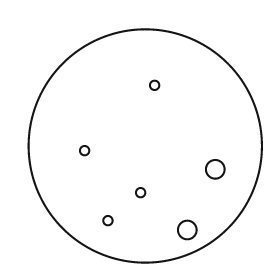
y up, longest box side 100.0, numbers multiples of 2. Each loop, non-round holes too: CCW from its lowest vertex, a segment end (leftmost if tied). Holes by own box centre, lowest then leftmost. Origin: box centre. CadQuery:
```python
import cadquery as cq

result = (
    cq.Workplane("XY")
    .moveTo(0.0, 0.0)
    .circle(50.0)
    .moveTo(18.0, -36.0)
    .circle(4.0)
    .moveTo(-16.0, -32.0)
    .circle(2.0)
    .moveTo(-2.0, -20.0)
    .circle(2.0)
    .moveTo(30.0, -10.0)
    .circle(4.0)
    .moveTo(-26.0, -2.0)
    .circle(2.0)
    .moveTo(4.0, 26.0)
    .circle(2.0)
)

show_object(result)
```